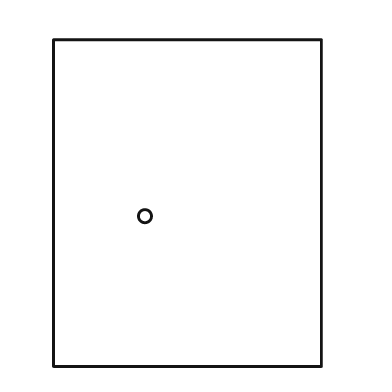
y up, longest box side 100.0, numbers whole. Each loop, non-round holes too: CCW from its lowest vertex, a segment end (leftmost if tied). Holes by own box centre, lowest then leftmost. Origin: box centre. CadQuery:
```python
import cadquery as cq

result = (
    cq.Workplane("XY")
    .moveTo(-41.0, -50.0)
    .lineTo(41.0, -50.0)
    .lineTo(41.0, 50.0)
    .lineTo(-41.0, 50.0)
    .close()
    .moveTo(-13.0, -4.0)
    .circle(2.0)
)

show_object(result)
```